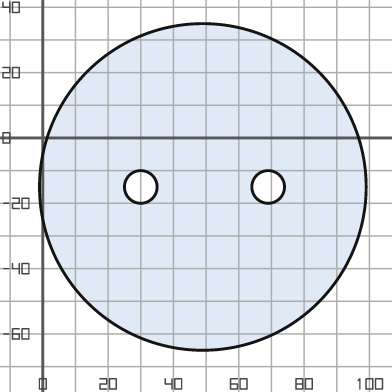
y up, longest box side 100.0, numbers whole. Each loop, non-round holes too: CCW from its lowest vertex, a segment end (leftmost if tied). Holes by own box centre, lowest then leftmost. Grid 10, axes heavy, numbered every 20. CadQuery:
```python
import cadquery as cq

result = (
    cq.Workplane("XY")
    .moveTo(49.0, -15.0)
    .circle(50.0)
    .moveTo(30.0, -15.0)
    .circle(5.0)
    .moveTo(69.0, -15.0)
    .circle(5.0)
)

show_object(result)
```